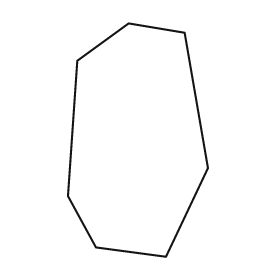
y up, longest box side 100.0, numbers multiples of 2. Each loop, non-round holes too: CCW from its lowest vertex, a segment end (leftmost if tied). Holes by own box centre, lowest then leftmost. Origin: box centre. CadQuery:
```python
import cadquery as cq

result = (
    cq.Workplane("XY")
    .moveTo(12.0, -50.0)
    .lineTo(30.0, -12.0)
    .lineTo(20.0, 46.0)
    .lineTo(-4.0, 50.0)
    .lineTo(-26.0, 34.0)
    .lineTo(-30.0, -24.0)
    .lineTo(-18.0, -46.0)
    .close()
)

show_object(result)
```